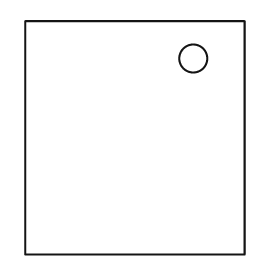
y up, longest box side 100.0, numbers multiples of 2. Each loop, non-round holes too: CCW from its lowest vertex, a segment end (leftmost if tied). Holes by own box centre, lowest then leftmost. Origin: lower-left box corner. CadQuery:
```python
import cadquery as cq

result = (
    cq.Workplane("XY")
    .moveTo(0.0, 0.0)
    .lineTo(94.0, 0.0)
    .lineTo(94.0, 100.0)
    .lineTo(0.0, 100.0)
    .close()
    .moveTo(72.0, 84.0)
    .circle(6.0)
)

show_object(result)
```